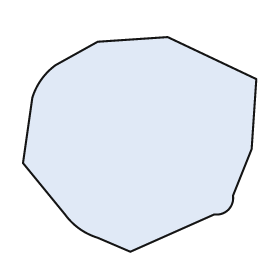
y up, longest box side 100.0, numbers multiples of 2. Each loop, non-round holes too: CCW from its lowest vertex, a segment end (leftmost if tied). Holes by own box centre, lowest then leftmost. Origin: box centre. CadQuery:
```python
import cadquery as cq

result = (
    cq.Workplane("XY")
    .moveTo(-4.0, -46.0)
    .lineTo(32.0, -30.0)
    .threePointArc((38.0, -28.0), (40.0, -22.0))
    .lineTo(48.0, -2.0)
    .lineTo(50.0, 28.0)
    .lineTo(12.0, 46.0)
    .lineTo(-18.0, 44.0)
    .lineTo(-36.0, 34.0)
    .threePointArc((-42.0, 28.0), (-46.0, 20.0))
    .lineTo(-50.0, -8.0)
    .lineTo(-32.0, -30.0)
    .threePointArc((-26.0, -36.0), (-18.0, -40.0))
    .close()
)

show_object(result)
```